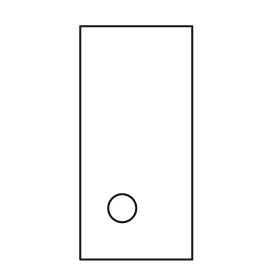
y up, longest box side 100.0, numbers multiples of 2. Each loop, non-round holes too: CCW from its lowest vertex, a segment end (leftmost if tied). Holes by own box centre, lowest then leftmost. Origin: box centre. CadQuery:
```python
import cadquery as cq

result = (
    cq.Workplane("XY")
    .moveTo(-24.0, -50.0)
    .lineTo(24.0, -50.0)
    .lineTo(24.0, 50.0)
    .lineTo(-24.0, 50.0)
    .close()
    .moveTo(-6.0, -28.0)
    .circle(6.0)
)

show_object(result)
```